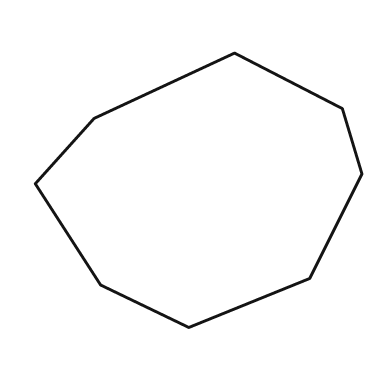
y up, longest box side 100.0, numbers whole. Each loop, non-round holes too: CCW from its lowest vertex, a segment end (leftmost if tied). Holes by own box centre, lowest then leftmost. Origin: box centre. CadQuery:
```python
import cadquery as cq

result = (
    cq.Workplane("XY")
    .moveTo(-3.0, -42.0)
    .lineTo(34.0, -27.0)
    .lineTo(50.0, 5.0)
    .lineTo(44.0, 25.0)
    .lineTo(11.0, 42.0)
    .lineTo(-32.0, 22.0)
    .lineTo(-50.0, 2.0)
    .lineTo(-30.0, -29.0)
    .close()
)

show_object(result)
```